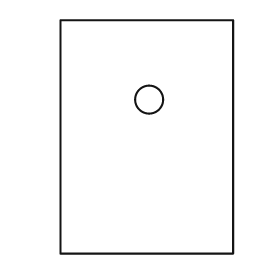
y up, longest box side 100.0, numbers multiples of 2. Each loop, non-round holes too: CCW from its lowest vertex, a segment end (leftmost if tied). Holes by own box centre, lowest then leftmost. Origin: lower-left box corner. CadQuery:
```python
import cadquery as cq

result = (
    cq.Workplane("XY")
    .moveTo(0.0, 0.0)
    .lineTo(74.0, 0.0)
    .lineTo(74.0, 100.0)
    .lineTo(0.0, 100.0)
    .close()
    .moveTo(38.0, 66.0)
    .circle(6.0)
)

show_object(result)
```